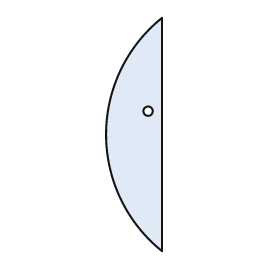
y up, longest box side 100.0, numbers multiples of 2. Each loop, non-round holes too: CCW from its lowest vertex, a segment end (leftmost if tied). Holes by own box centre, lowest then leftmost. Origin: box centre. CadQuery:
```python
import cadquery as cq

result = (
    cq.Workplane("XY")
    .moveTo(12.0, -50.0)
    .lineTo(12.0, 50.0)
    .threePointArc((-12.0, 0.0), (12.0, -50.0))
    .close()
    .moveTo(6.0, 10.0)
    .circle(2.0)
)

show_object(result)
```